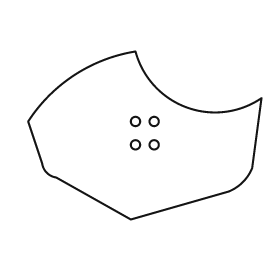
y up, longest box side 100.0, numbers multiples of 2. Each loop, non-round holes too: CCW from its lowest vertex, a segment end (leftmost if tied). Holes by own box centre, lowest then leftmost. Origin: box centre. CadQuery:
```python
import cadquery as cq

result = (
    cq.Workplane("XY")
    .moveTo(-6.0, -36.0)
    .lineTo(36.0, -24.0)
    .threePointArc((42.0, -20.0), (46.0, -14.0))
    .lineTo(50.0, 16.0)
    .threePointArc((18.0, 12.0), (-4.0, 36.0))
    .threePointArc((-30.0, 26.0), (-50.0, 6.0))
    .lineTo(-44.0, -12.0)
    .threePointArc((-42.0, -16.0), (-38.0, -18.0))
    .close()
    .moveTo(-4.0, -4.0)
    .circle(2.0)
    .moveTo(4.0, -4.0)
    .circle(2.0)
    .moveTo(-4.0, 6.0)
    .circle(2.0)
    .moveTo(4.0, 6.0)
    .circle(2.0)
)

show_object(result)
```